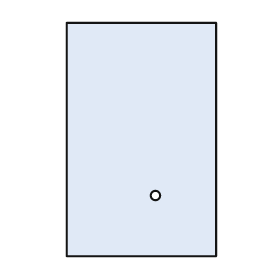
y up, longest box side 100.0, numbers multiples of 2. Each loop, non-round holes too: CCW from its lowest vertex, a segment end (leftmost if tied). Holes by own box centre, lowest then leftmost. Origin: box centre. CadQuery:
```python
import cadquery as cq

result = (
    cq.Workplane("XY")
    .moveTo(-32.0, -50.0)
    .lineTo(32.0, -50.0)
    .lineTo(32.0, 50.0)
    .lineTo(-32.0, 50.0)
    .close()
    .moveTo(6.0, -24.0)
    .circle(2.0)
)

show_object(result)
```